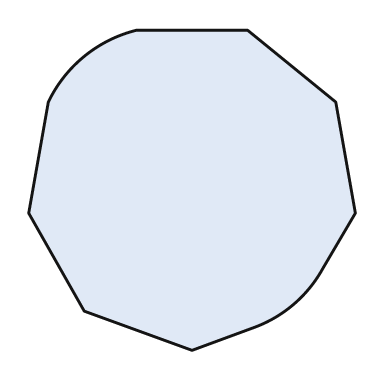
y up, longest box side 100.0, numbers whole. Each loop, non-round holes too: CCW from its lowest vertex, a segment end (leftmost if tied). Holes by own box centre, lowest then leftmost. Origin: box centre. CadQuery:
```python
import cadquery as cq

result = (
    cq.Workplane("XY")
    .moveTo(0.0, -49.0)
    .lineTo(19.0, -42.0)
    .threePointArc((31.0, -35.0), (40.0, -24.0))
    .lineTo(50.0, -7.0)
    .lineTo(44.0, 27.0)
    .lineTo(17.0, 49.0)
    .lineTo(-17.0, 49.0)
    .threePointArc((-33.0, 41.0), (-44.0, 27.0))
    .lineTo(-50.0, -7.0)
    .lineTo(-33.0, -37.0)
    .close()
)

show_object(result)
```